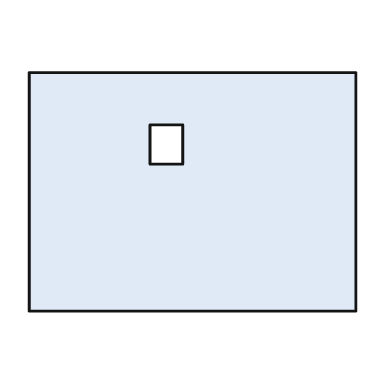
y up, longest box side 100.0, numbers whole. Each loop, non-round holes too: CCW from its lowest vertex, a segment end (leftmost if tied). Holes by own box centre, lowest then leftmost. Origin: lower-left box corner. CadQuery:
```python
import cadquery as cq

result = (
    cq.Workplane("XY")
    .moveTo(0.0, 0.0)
    .lineTo(100.0, 0.0)
    .lineTo(100.0, 73.0)
    .lineTo(0.0, 73.0)
    .close()
    .moveTo(37.0, 45.0)
    .lineTo(47.0, 45.0)
    .lineTo(47.0, 57.0)
    .lineTo(37.0, 57.0)
    .close()
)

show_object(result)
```